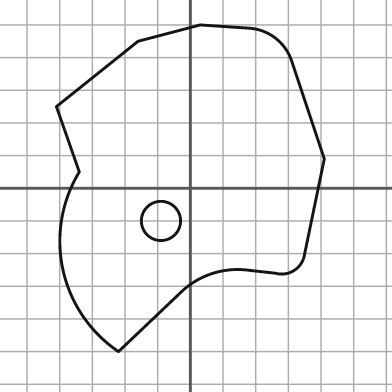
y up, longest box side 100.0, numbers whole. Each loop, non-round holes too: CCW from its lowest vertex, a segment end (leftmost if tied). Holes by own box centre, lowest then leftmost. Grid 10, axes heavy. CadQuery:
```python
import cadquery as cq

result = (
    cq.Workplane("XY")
    .moveTo(-22.0, -50.0)
    .lineTo(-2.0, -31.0)
    .threePointArc((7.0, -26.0), (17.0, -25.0))
    .lineTo(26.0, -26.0)
    .threePointArc((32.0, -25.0), (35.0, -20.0))
    .lineTo(41.0, 9.0)
    .lineTo(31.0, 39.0)
    .threePointArc((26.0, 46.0), (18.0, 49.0))
    .lineTo(3.0, 50.0)
    .lineTo(-16.0, 45.0)
    .lineTo(-41.0, 25.0)
    .lineTo(-34.0, 5.0)
    .threePointArc((-39.0, -25.0), (-22.0, -50.0))
    .close()
    .moveTo(-9.0, -10.0)
    .circle(6.0)
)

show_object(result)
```